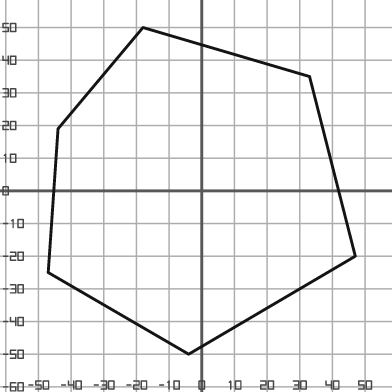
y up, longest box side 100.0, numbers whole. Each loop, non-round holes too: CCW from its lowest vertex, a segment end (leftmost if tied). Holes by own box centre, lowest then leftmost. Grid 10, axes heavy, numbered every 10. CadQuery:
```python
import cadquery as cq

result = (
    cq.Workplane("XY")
    .moveTo(-4.0, -50.0)
    .lineTo(47.0, -20.0)
    .lineTo(33.0, 35.0)
    .lineTo(-18.0, 50.0)
    .lineTo(-44.0, 19.0)
    .lineTo(-47.0, -25.0)
    .close()
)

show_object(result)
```